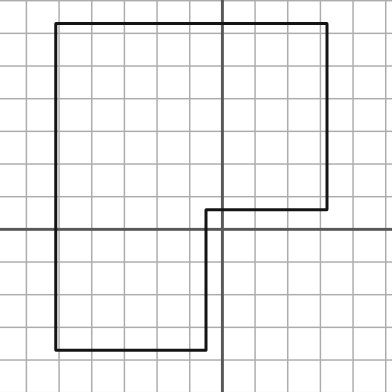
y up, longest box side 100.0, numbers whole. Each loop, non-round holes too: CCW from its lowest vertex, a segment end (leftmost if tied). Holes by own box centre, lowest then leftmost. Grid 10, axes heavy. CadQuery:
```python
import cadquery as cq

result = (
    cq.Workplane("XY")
    .moveTo(-51.0, -37.0)
    .lineTo(-5.0, -37.0)
    .lineTo(-5.0, 6.0)
    .lineTo(32.0, 6.0)
    .lineTo(32.0, 63.0)
    .lineTo(-51.0, 63.0)
    .close()
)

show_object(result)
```